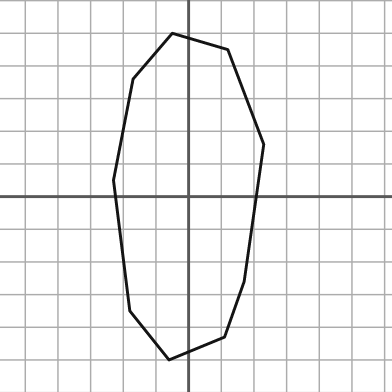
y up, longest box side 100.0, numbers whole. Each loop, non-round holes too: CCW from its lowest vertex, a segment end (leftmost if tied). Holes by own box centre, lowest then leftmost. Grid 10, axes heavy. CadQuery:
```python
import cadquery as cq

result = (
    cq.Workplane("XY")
    .moveTo(-6.0, -50.0)
    .lineTo(11.0, -43.0)
    .lineTo(17.0, -26.0)
    .lineTo(23.0, 16.0)
    .lineTo(12.0, 45.0)
    .lineTo(-5.0, 50.0)
    .lineTo(-17.0, 36.0)
    .lineTo(-23.0, 5.0)
    .lineTo(-18.0, -35.0)
    .close()
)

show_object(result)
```